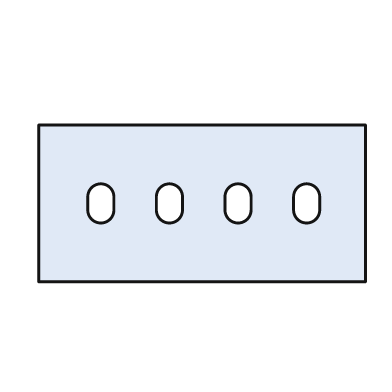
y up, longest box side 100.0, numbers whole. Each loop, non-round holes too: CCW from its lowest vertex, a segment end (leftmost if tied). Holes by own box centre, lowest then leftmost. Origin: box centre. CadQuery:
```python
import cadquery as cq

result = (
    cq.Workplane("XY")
    .moveTo(-50.0, -24.0)
    .lineTo(50.0, -24.0)
    .lineTo(50.0, 24.0)
    .lineTo(-50.0, 24.0)
    .close()
    .moveTo(-35.0, -2.0)
    .threePointArc((-31.0, -6.0), (-27.0, -2.0))
    .lineTo(-27.0, 2.0)
    .threePointArc((-31.0, 6.0), (-35.0, 2.0))
    .close()
    .moveTo(-14.0, -2.0)
    .threePointArc((-10.0, -6.0), (-6.0, -2.0))
    .lineTo(-6.0, 2.0)
    .threePointArc((-10.0, 6.0), (-14.0, 2.0))
    .close()
    .moveTo(7.0, -2.0)
    .threePointArc((11.0, -6.0), (15.0, -2.0))
    .lineTo(15.0, 2.0)
    .threePointArc((11.0, 6.0), (7.0, 2.0))
    .close()
    .moveTo(28.0, -2.0)
    .threePointArc((32.0, -6.0), (36.0, -2.0))
    .lineTo(36.0, 2.0)
    .threePointArc((32.0, 6.0), (28.0, 2.0))
    .close()
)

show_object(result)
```